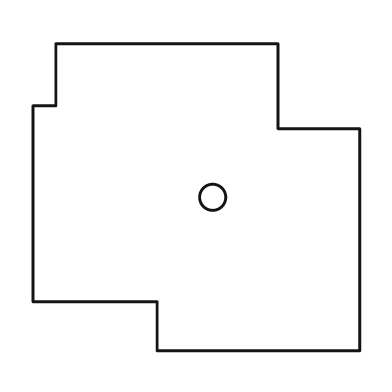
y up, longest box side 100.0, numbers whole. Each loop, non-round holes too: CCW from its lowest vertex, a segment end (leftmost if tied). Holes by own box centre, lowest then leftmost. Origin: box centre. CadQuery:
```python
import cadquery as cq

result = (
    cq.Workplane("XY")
    .moveTo(-12.0, -47.0)
    .lineTo(50.0, -47.0)
    .lineTo(50.0, 21.0)
    .lineTo(25.0, 21.0)
    .lineTo(25.0, 47.0)
    .lineTo(-43.0, 47.0)
    .lineTo(-43.0, 28.0)
    .lineTo(-50.0, 28.0)
    .lineTo(-50.0, -32.0)
    .lineTo(-12.0, -32.0)
    .close()
    .moveTo(5.0, 0.0)
    .circle(4.0)
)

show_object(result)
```